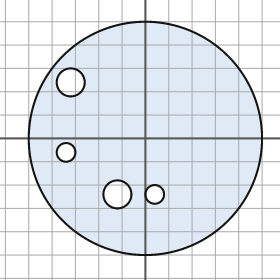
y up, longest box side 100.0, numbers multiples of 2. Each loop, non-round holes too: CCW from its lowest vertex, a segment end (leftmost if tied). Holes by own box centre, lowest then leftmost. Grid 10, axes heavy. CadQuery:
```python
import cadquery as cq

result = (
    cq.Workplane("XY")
    .moveTo(0.0, 0.0)
    .circle(50.0)
    .moveTo(-12.0, -24.0)
    .circle(6.0)
    .moveTo(4.0, -24.0)
    .circle(4.0)
    .moveTo(-34.0, -6.0)
    .circle(4.0)
    .moveTo(-32.0, 24.0)
    .circle(6.0)
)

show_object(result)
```